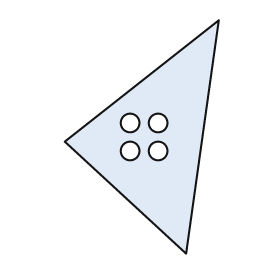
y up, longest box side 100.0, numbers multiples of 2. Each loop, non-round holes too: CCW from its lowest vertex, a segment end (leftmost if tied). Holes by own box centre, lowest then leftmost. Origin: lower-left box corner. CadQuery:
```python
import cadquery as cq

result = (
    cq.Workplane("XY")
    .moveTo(52.0, 0.0)
    .lineTo(66.0, 100.0)
    .lineTo(0.0, 48.0)
    .close()
    .moveTo(28.0, 44.0)
    .circle(4.0)
    .moveTo(40.0, 44.0)
    .circle(4.0)
    .moveTo(28.0, 56.0)
    .circle(4.0)
    .moveTo(40.0, 56.0)
    .circle(4.0)
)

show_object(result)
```